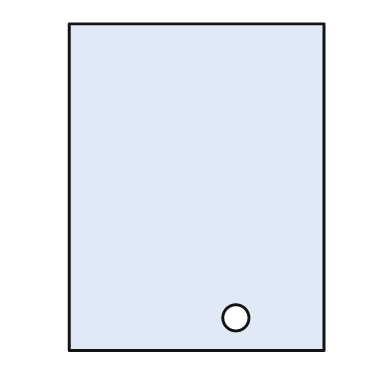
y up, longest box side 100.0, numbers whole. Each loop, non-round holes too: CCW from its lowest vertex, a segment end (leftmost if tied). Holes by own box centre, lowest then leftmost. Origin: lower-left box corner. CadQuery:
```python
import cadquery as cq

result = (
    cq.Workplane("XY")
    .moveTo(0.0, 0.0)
    .lineTo(78.0, 0.0)
    .lineTo(78.0, 100.0)
    .lineTo(0.0, 100.0)
    .close()
    .moveTo(51.0, 10.0)
    .circle(4.0)
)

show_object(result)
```